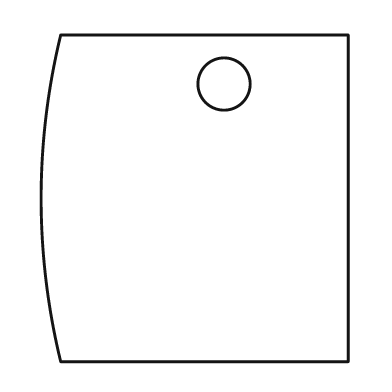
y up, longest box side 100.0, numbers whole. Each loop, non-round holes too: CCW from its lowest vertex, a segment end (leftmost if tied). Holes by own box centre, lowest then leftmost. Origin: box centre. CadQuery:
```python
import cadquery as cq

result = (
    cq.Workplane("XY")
    .moveTo(-41.0, -50.0)
    .lineTo(47.0, -50.0)
    .lineTo(47.0, 50.0)
    .lineTo(-41.0, 50.0)
    .threePointArc((-47.0, 0.0), (-41.0, -50.0))
    .close()
    .moveTo(9.0, 35.0)
    .circle(8.0)
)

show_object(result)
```